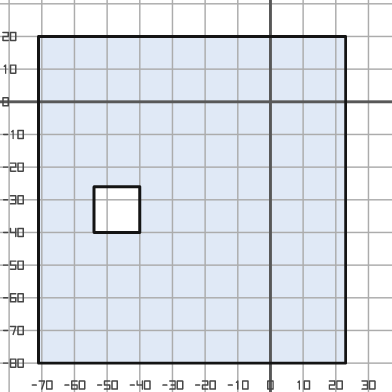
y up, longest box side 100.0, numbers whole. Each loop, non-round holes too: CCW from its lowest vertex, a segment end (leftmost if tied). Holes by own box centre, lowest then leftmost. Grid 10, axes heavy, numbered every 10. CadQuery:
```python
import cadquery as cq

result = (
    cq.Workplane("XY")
    .moveTo(-71.0, -80.0)
    .lineTo(23.0, -80.0)
    .lineTo(23.0, 20.0)
    .lineTo(-71.0, 20.0)
    .close()
    .moveTo(-54.0, -40.0)
    .lineTo(-40.0, -40.0)
    .lineTo(-40.0, -26.0)
    .lineTo(-54.0, -26.0)
    .close()
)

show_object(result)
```